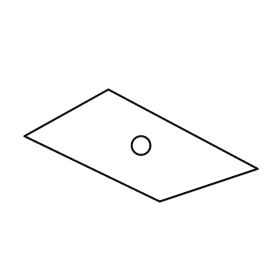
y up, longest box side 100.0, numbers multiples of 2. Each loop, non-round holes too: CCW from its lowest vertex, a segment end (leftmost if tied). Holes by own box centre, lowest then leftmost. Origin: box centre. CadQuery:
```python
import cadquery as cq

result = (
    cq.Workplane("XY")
    .moveTo(8.0, -24.0)
    .lineTo(50.0, -10.0)
    .lineTo(-14.0, 24.0)
    .lineTo(-50.0, 4.0)
    .close()
    .moveTo(0.0, 0.0)
    .circle(4.0)
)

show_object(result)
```